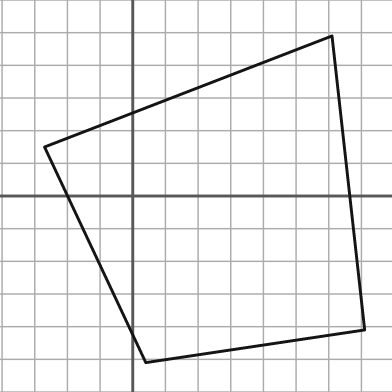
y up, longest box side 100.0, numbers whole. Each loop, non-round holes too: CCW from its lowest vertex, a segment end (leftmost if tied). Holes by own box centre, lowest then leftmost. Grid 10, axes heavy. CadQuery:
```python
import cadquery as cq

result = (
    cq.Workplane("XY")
    .moveTo(4.0, -51.0)
    .lineTo(71.0, -41.0)
    .lineTo(61.0, 49.0)
    .lineTo(-27.0, 15.0)
    .close()
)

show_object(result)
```